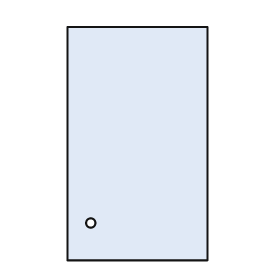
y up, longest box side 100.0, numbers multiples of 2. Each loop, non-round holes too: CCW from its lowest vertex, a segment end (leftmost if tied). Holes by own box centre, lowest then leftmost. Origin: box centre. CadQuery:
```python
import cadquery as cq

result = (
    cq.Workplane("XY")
    .moveTo(-30.0, -50.0)
    .lineTo(30.0, -50.0)
    .lineTo(30.0, 50.0)
    .lineTo(-30.0, 50.0)
    .close()
    .moveTo(-20.0, -34.0)
    .circle(2.0)
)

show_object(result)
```